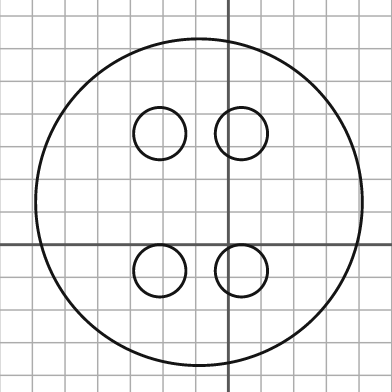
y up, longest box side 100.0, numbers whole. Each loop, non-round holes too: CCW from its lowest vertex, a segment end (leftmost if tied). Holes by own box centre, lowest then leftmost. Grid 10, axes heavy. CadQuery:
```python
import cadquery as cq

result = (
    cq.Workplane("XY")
    .moveTo(-9.0, 13.0)
    .circle(50.0)
    .moveTo(-21.0, -8.0)
    .circle(8.0)
    .moveTo(4.0, -8.0)
    .circle(8.0)
    .moveTo(-21.0, 34.0)
    .circle(8.0)
    .moveTo(4.0, 34.0)
    .circle(8.0)
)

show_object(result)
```